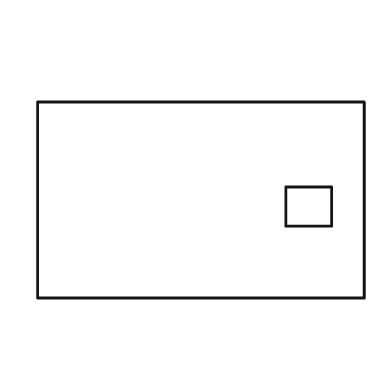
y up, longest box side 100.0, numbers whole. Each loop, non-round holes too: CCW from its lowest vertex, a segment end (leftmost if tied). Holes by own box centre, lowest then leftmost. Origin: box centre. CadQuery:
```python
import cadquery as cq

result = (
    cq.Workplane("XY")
    .moveTo(-50.0, -30.0)
    .lineTo(50.0, -30.0)
    .lineTo(50.0, 30.0)
    .lineTo(-50.0, 30.0)
    .close()
    .moveTo(26.0, -8.0)
    .lineTo(40.0, -8.0)
    .lineTo(40.0, 4.0)
    .lineTo(26.0, 4.0)
    .close()
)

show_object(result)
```